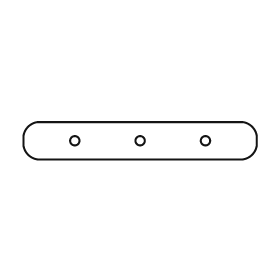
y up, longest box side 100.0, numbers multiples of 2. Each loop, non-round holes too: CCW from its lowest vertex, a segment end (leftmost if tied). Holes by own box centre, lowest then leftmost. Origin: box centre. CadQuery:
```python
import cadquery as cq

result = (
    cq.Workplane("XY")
    .moveTo(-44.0, -8.0)
    .lineTo(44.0, -8.0)
    .threePointArc((48.0, -6.0), (50.0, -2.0))
    .lineTo(50.0, 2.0)
    .threePointArc((48.0, 6.0), (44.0, 8.0))
    .lineTo(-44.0, 8.0)
    .threePointArc((-48.0, 6.0), (-50.0, 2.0))
    .lineTo(-50.0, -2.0)
    .threePointArc((-48.0, -6.0), (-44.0, -8.0))
    .close()
    .moveTo(-28.0, 0.0)
    .circle(2.0)
    .moveTo(0.0, 0.0)
    .circle(2.0)
    .moveTo(28.0, 0.0)
    .circle(2.0)
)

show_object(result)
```